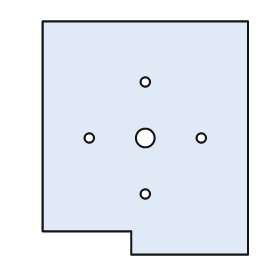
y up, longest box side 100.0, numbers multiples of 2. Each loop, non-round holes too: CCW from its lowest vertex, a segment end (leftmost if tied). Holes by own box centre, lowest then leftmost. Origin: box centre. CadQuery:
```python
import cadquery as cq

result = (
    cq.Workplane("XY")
    .moveTo(-6.0, -50.0)
    .lineTo(44.0, -50.0)
    .lineTo(44.0, 50.0)
    .lineTo(-44.0, 50.0)
    .lineTo(-44.0, -40.0)
    .lineTo(-6.0, -40.0)
    .close()
    .moveTo(0.0, -24.0)
    .circle(2.0)
    .moveTo(-24.0, 0.0)
    .circle(2.0)
    .moveTo(0.0, 0.0)
    .circle(4.0)
    .moveTo(24.0, 0.0)
    .circle(2.0)
    .moveTo(0.0, 24.0)
    .circle(2.0)
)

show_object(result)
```